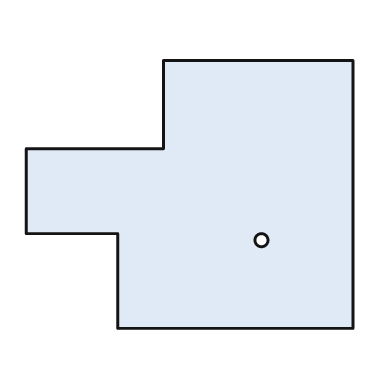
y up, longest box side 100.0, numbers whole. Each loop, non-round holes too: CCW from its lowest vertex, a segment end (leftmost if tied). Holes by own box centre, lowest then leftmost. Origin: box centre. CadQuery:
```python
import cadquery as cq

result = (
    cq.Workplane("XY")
    .moveTo(-22.0, -41.0)
    .lineTo(50.0, -41.0)
    .lineTo(50.0, 41.0)
    .lineTo(-8.0, 41.0)
    .lineTo(-8.0, 14.0)
    .lineTo(-50.0, 14.0)
    .lineTo(-50.0, -12.0)
    .lineTo(-22.0, -12.0)
    .close()
    .moveTo(22.0, -14.0)
    .circle(2.0)
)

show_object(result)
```